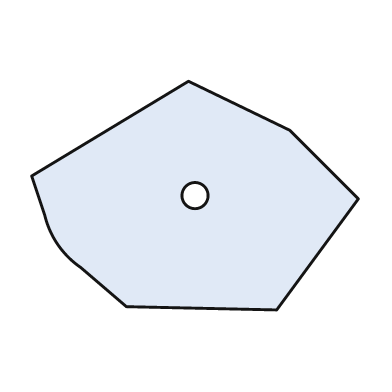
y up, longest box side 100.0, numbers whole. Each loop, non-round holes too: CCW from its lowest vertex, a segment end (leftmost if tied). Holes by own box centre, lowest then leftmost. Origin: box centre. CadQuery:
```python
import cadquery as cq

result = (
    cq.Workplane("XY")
    .moveTo(25.0, -35.0)
    .lineTo(50.0, -1.0)
    .lineTo(29.0, 20.0)
    .lineTo(-2.0, 35.0)
    .lineTo(-50.0, 6.0)
    .lineTo(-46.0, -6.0)
    .threePointArc((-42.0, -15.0), (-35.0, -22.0))
    .lineTo(-21.0, -34.0)
    .close()
    .moveTo(0.0, 0.0)
    .circle(4.0)
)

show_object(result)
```